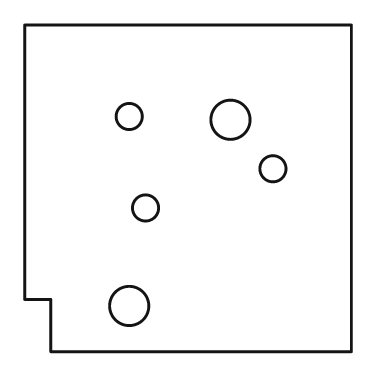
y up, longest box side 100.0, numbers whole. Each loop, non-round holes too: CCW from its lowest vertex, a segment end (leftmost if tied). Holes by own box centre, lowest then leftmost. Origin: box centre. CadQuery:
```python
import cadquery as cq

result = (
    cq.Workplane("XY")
    .moveTo(-42.0, -50.0)
    .lineTo(50.0, -50.0)
    .lineTo(50.0, 50.0)
    .lineTo(-50.0, 50.0)
    .lineTo(-50.0, -34.0)
    .lineTo(-42.0, -34.0)
    .close()
    .moveTo(-18.0, -36.0)
    .circle(6.0)
    .moveTo(-13.0, -6.0)
    .circle(4.0)
    .moveTo(26.0, 6.0)
    .circle(4.0)
    .moveTo(13.0, 21.0)
    .circle(6.0)
    .moveTo(-18.0, 22.0)
    .circle(4.0)
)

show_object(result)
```